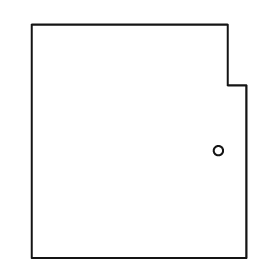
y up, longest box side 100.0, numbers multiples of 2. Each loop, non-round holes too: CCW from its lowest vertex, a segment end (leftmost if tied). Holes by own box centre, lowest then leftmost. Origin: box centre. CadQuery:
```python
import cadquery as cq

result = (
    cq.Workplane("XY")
    .moveTo(-46.0, -50.0)
    .lineTo(46.0, -50.0)
    .lineTo(46.0, 24.0)
    .lineTo(38.0, 24.0)
    .lineTo(38.0, 50.0)
    .lineTo(-46.0, 50.0)
    .close()
    .moveTo(34.0, -4.0)
    .circle(2.0)
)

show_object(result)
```